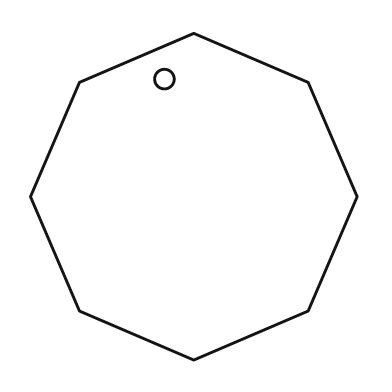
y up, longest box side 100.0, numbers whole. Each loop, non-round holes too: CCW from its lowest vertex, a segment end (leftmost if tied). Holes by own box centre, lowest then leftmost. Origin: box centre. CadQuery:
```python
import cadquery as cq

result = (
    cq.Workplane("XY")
    .moveTo(0.0, -50.0)
    .lineTo(35.0, -35.0)
    .lineTo(50.0, 0.0)
    .lineTo(35.0, 35.0)
    .lineTo(0.0, 50.0)
    .lineTo(-35.0, 35.0)
    .lineTo(-50.0, 0.0)
    .lineTo(-35.0, -35.0)
    .close()
    .moveTo(-9.0, 36.0)
    .circle(3.0)
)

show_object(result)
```